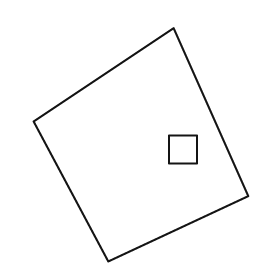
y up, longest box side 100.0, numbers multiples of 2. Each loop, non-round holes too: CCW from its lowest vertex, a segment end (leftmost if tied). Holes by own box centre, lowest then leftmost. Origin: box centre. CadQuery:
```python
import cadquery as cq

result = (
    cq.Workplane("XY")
    .moveTo(-14.0, -50.0)
    .lineTo(46.0, -22.0)
    .lineTo(14.0, 50.0)
    .lineTo(-46.0, 10.0)
    .close()
    .moveTo(12.0, -8.0)
    .lineTo(24.0, -8.0)
    .lineTo(24.0, 4.0)
    .lineTo(12.0, 4.0)
    .close()
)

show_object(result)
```